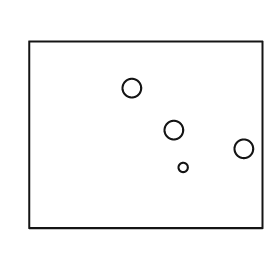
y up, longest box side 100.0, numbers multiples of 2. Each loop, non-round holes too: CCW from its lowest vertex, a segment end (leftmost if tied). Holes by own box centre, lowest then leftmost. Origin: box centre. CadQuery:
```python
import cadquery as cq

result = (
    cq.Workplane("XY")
    .moveTo(-50.0, -40.0)
    .lineTo(50.0, -40.0)
    .lineTo(50.0, 40.0)
    .lineTo(-50.0, 40.0)
    .close()
    .moveTo(16.0, -14.0)
    .circle(2.0)
    .moveTo(42.0, -6.0)
    .circle(4.0)
    .moveTo(12.0, 2.0)
    .circle(4.0)
    .moveTo(-6.0, 20.0)
    .circle(4.0)
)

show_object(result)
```